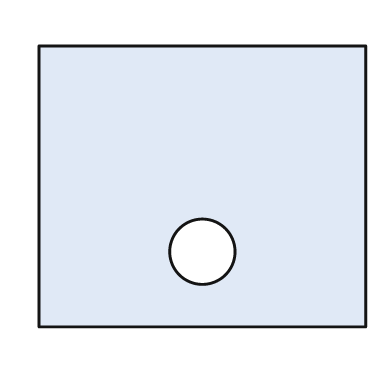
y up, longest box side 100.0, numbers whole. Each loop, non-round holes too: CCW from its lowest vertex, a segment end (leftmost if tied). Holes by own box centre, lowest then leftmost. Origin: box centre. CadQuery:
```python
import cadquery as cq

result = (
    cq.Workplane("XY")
    .moveTo(-50.0, -43.0)
    .lineTo(50.0, -43.0)
    .lineTo(50.0, 43.0)
    .lineTo(-50.0, 43.0)
    .close()
    .moveTo(0.0, -20.0)
    .circle(10.0)
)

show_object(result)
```